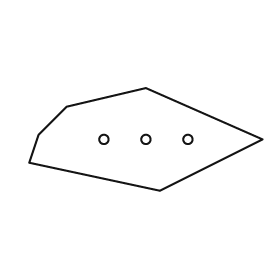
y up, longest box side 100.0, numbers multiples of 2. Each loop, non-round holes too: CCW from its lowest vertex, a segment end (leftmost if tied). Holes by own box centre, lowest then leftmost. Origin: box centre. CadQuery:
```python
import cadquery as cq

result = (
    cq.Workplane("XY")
    .moveTo(6.0, -22.0)
    .lineTo(50.0, 0.0)
    .lineTo(0.0, 22.0)
    .lineTo(-34.0, 14.0)
    .lineTo(-46.0, 2.0)
    .lineTo(-50.0, -10.0)
    .close()
    .moveTo(-18.0, 0.0)
    .circle(2.0)
    .moveTo(0.0, 0.0)
    .circle(2.0)
    .moveTo(18.0, 0.0)
    .circle(2.0)
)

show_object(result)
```